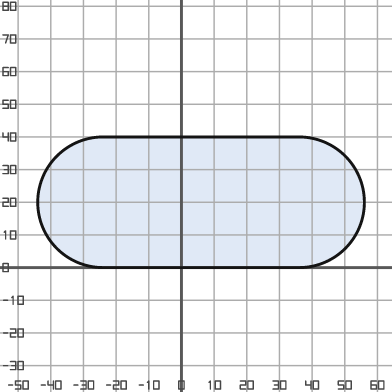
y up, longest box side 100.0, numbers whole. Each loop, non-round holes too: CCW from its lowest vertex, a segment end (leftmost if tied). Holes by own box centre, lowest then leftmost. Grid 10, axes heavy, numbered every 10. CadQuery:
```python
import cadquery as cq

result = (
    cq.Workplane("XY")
    .moveTo(-24.0, 0.0)
    .lineTo(36.0, 0.0)
    .threePointArc((56.0, 20.0), (36.0, 40.0))
    .lineTo(-24.0, 40.0)
    .threePointArc((-44.0, 20.0), (-24.0, 0.0))
    .close()
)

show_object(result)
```